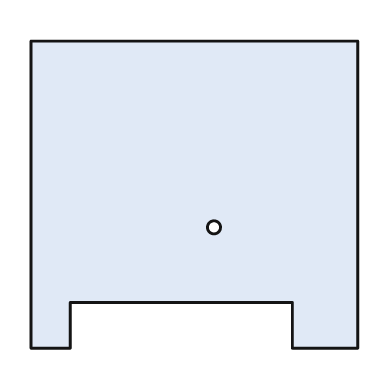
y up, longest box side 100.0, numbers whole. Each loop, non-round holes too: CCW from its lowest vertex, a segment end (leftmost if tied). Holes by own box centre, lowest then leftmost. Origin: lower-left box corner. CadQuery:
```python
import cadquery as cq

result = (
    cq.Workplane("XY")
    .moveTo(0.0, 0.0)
    .lineTo(12.0, 0.0)
    .lineTo(12.0, 14.0)
    .lineTo(80.0, 14.0)
    .lineTo(80.0, 0.0)
    .lineTo(100.0, 0.0)
    .lineTo(100.0, 94.0)
    .lineTo(0.0, 94.0)
    .close()
    .moveTo(56.0, 37.0)
    .circle(2.0)
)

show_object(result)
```